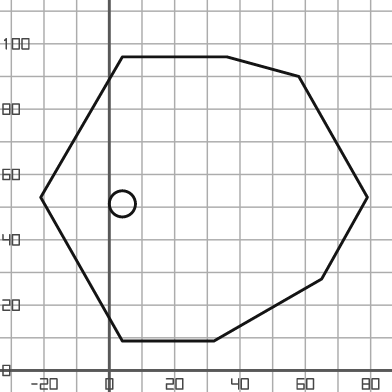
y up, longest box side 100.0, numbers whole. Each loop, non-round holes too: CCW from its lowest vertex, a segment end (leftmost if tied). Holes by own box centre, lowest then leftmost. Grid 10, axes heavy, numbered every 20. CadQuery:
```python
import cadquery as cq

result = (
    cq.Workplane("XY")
    .moveTo(4.0, 9.0)
    .lineTo(32.0, 9.0)
    .lineTo(65.0, 28.0)
    .lineTo(79.0, 53.0)
    .lineTo(58.0, 90.0)
    .lineTo(36.0, 96.0)
    .lineTo(4.0, 96.0)
    .lineTo(-21.0, 53.0)
    .close()
    .moveTo(4.0, 51.0)
    .circle(4.0)
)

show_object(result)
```